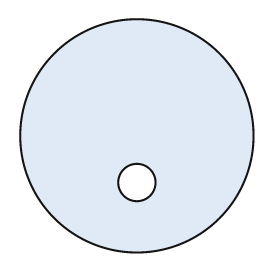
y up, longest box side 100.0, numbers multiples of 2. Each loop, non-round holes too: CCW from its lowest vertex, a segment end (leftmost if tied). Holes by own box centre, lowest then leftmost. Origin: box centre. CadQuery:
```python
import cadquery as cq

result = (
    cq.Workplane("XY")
    .moveTo(0.0, 0.0)
    .circle(50.0)
    .moveTo(0.0, -20.0)
    .circle(8.0)
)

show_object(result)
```